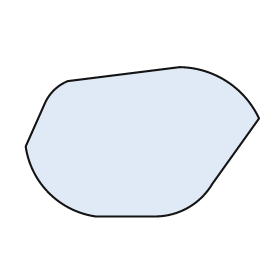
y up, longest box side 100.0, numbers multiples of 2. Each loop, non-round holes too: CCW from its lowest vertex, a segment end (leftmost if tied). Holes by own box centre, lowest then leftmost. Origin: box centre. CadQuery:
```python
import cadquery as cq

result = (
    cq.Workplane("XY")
    .moveTo(-20.0, -32.0)
    .lineTo(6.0, -32.0)
    .threePointArc((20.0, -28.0), (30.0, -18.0))
    .lineTo(50.0, 10.0)
    .threePointArc((36.0, 26.0), (16.0, 32.0))
    .lineTo(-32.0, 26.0)
    .threePointArc((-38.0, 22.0), (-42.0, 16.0))
    .lineTo(-50.0, -2.0)
    .threePointArc((-40.0, -22.0), (-20.0, -32.0))
    .close()
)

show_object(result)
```